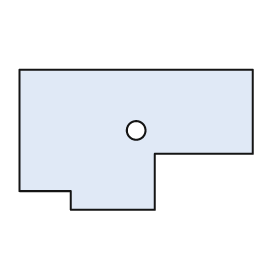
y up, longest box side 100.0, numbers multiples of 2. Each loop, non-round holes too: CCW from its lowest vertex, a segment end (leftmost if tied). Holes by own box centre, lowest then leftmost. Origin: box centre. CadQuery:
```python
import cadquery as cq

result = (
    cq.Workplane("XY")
    .moveTo(-28.0, -30.0)
    .lineTo(8.0, -30.0)
    .lineTo(8.0, -6.0)
    .lineTo(50.0, -6.0)
    .lineTo(50.0, 30.0)
    .lineTo(-50.0, 30.0)
    .lineTo(-50.0, -22.0)
    .lineTo(-28.0, -22.0)
    .close()
    .moveTo(0.0, 4.0)
    .circle(4.0)
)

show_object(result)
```